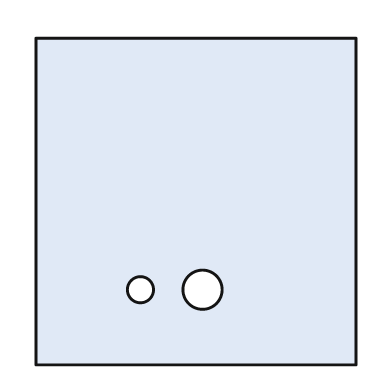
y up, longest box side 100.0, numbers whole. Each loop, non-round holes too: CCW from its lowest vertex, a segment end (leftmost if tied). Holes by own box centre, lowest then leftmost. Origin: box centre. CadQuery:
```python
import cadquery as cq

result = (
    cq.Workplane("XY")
    .moveTo(-49.0, -50.0)
    .lineTo(49.0, -50.0)
    .lineTo(49.0, 50.0)
    .lineTo(-49.0, 50.0)
    .close()
    .moveTo(-17.0, -27.0)
    .circle(4.0)
    .moveTo(2.0, -27.0)
    .circle(6.0)
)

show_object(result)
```